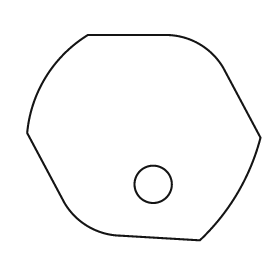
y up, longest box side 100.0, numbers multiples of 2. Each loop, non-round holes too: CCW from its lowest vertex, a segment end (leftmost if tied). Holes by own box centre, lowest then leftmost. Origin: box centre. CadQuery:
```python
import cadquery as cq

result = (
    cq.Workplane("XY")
    .moveTo(24.0, -44.0)
    .threePointArc((40.0, -24.0), (50.0, 0.0))
    .lineTo(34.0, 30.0)
    .threePointArc((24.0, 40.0), (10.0, 44.0))
    .lineTo(-24.0, 44.0)
    .threePointArc((-42.0, 26.0), (-50.0, 2.0))
    .lineTo(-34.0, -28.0)
    .threePointArc((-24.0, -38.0), (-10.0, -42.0))
    .close()
    .moveTo(4.0, -20.0)
    .circle(8.0)
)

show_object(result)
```